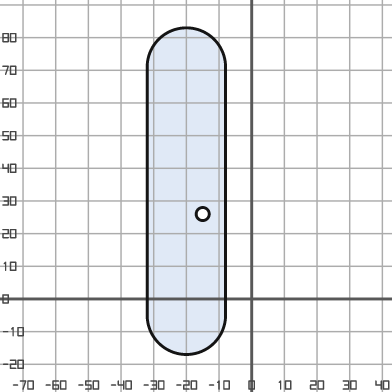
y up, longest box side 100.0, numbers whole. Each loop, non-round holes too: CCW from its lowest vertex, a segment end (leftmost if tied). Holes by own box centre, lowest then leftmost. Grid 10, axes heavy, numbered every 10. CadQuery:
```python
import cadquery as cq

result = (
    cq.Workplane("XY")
    .moveTo(-32.0, -5.0)
    .threePointArc((-20.0, -17.0), (-8.0, -5.0))
    .lineTo(-8.0, 71.0)
    .threePointArc((-20.0, 83.0), (-32.0, 71.0))
    .close()
    .moveTo(-15.0, 26.0)
    .circle(2.0)
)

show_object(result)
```